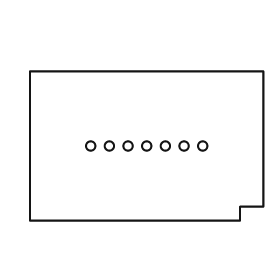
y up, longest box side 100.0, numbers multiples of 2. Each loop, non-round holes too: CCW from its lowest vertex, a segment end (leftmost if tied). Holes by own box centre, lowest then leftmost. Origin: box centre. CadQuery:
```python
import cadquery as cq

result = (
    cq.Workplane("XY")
    .moveTo(-50.0, -32.0)
    .lineTo(40.0, -32.0)
    .lineTo(40.0, -26.0)
    .lineTo(50.0, -26.0)
    .lineTo(50.0, 32.0)
    .lineTo(-50.0, 32.0)
    .close()
    .moveTo(-24.0, 0.0)
    .circle(2.0)
    .moveTo(-16.0, 0.0)
    .circle(2.0)
    .moveTo(-8.0, 0.0)
    .circle(2.0)
    .moveTo(0.0, 0.0)
    .circle(2.0)
    .moveTo(8.0, 0.0)
    .circle(2.0)
    .moveTo(16.0, 0.0)
    .circle(2.0)
    .moveTo(24.0, 0.0)
    .circle(2.0)
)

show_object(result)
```